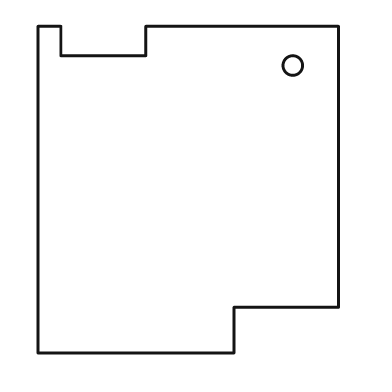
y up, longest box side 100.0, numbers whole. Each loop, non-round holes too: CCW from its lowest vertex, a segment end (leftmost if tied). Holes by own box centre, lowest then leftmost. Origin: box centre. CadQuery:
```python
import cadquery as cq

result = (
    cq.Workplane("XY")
    .moveTo(-46.0, -50.0)
    .lineTo(14.0, -50.0)
    .lineTo(14.0, -36.0)
    .lineTo(46.0, -36.0)
    .lineTo(46.0, 50.0)
    .lineTo(-13.0, 50.0)
    .lineTo(-13.0, 41.0)
    .lineTo(-39.0, 41.0)
    .lineTo(-39.0, 50.0)
    .lineTo(-46.0, 50.0)
    .close()
    .moveTo(32.0, 38.0)
    .circle(3.0)
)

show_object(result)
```